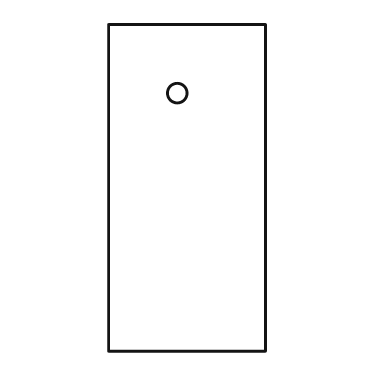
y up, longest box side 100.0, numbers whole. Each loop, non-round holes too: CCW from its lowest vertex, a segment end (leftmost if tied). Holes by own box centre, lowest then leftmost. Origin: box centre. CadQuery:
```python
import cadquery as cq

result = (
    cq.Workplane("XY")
    .moveTo(-24.0, -50.0)
    .lineTo(24.0, -50.0)
    .lineTo(24.0, 50.0)
    .lineTo(-24.0, 50.0)
    .close()
    .moveTo(-3.0, 29.0)
    .circle(3.0)
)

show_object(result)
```